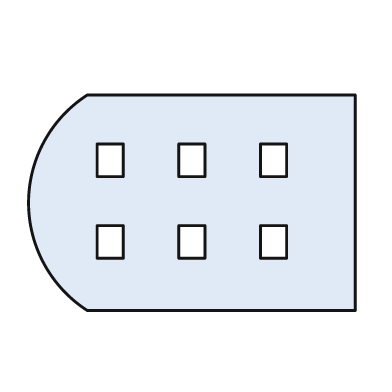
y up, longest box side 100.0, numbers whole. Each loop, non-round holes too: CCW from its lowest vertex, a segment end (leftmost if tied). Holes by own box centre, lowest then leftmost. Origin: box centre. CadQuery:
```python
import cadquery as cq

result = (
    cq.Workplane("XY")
    .moveTo(-32.0, -33.0)
    .lineTo(50.0, -33.0)
    .lineTo(50.0, 33.0)
    .lineTo(-32.0, 33.0)
    .threePointArc((-50.0, 0.0), (-32.0, -33.0))
    .close()
    .moveTo(-29.0, -17.0)
    .lineTo(-21.0, -17.0)
    .lineTo(-21.0, -7.0)
    .lineTo(-29.0, -7.0)
    .close()
    .moveTo(-4.0, -17.0)
    .lineTo(4.0, -17.0)
    .lineTo(4.0, -7.0)
    .lineTo(-4.0, -7.0)
    .close()
    .moveTo(21.0, -17.0)
    .lineTo(29.0, -17.0)
    .lineTo(29.0, -7.0)
    .lineTo(21.0, -7.0)
    .close()
    .moveTo(-29.0, 8.0)
    .lineTo(-21.0, 8.0)
    .lineTo(-21.0, 18.0)
    .lineTo(-29.0, 18.0)
    .close()
    .moveTo(-4.0, 8.0)
    .lineTo(4.0, 8.0)
    .lineTo(4.0, 18.0)
    .lineTo(-4.0, 18.0)
    .close()
    .moveTo(21.0, 8.0)
    .lineTo(29.0, 8.0)
    .lineTo(29.0, 18.0)
    .lineTo(21.0, 18.0)
    .close()
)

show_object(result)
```